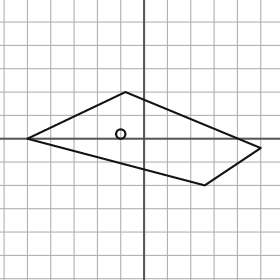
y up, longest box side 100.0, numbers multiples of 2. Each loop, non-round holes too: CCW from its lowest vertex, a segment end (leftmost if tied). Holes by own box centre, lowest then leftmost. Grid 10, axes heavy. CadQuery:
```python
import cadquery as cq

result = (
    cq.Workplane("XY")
    .moveTo(26.0, -20.0)
    .lineTo(50.0, -4.0)
    .lineTo(-8.0, 20.0)
    .lineTo(-50.0, 0.0)
    .close()
    .moveTo(-10.0, 2.0)
    .circle(2.0)
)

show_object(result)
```